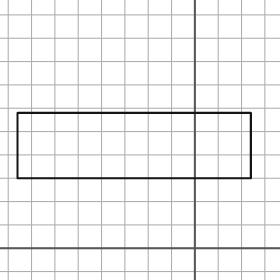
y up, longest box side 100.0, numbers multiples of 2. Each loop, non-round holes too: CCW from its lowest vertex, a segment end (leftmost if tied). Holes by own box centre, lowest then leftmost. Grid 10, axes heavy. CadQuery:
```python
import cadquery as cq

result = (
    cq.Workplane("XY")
    .moveTo(-76.0, 30.0)
    .lineTo(24.0, 30.0)
    .lineTo(24.0, 58.0)
    .lineTo(-76.0, 58.0)
    .close()
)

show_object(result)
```